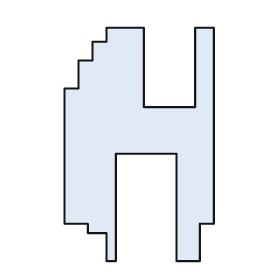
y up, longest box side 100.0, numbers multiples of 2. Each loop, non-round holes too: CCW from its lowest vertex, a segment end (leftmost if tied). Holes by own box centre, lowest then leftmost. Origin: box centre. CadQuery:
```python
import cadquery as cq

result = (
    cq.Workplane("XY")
    .moveTo(-14.0, -50.0)
    .lineTo(-10.0, -50.0)
    .lineTo(-10.0, -4.0)
    .lineTo(16.0, -4.0)
    .lineTo(16.0, -50.0)
    .lineTo(26.0, -50.0)
    .lineTo(26.0, -34.0)
    .lineTo(32.0, -34.0)
    .lineTo(32.0, 50.0)
    .lineTo(24.0, 50.0)
    .lineTo(24.0, 16.0)
    .lineTo(2.0, 16.0)
    .lineTo(2.0, 50.0)
    .lineTo(-14.0, 50.0)
    .lineTo(-14.0, 44.0)
    .lineTo(-20.0, 44.0)
    .lineTo(-20.0, 36.0)
    .lineTo(-26.0, 36.0)
    .lineTo(-26.0, 24.0)
    .lineTo(-32.0, 24.0)
    .lineTo(-32.0, -34.0)
    .lineTo(-22.0, -34.0)
    .lineTo(-22.0, -38.0)
    .lineTo(-14.0, -38.0)
    .close()
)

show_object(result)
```